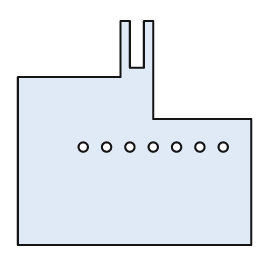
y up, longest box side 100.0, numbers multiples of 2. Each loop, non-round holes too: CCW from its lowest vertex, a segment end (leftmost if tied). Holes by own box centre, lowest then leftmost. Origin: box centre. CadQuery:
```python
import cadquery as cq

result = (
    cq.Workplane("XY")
    .moveTo(-50.0, -48.0)
    .lineTo(50.0, -48.0)
    .lineTo(50.0, 6.0)
    .lineTo(8.0, 6.0)
    .lineTo(8.0, 48.0)
    .lineTo(4.0, 48.0)
    .lineTo(4.0, 28.0)
    .lineTo(-2.0, 28.0)
    .lineTo(-2.0, 48.0)
    .lineTo(-6.0, 48.0)
    .lineTo(-6.0, 24.0)
    .lineTo(-50.0, 24.0)
    .close()
    .moveTo(-22.0, -6.0)
    .circle(2.0)
    .moveTo(-12.0, -6.0)
    .circle(2.0)
    .moveTo(-2.0, -6.0)
    .circle(2.0)
    .moveTo(8.0, -6.0)
    .circle(2.0)
    .moveTo(18.0, -6.0)
    .circle(2.0)
    .moveTo(28.0, -6.0)
    .circle(2.0)
    .moveTo(38.0, -6.0)
    .circle(2.0)
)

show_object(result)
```